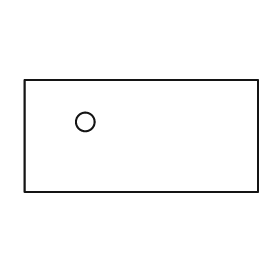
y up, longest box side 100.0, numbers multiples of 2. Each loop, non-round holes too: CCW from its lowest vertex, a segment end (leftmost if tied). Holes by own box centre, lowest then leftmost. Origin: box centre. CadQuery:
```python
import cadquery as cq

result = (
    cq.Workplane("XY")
    .moveTo(-50.0, -24.0)
    .lineTo(50.0, -24.0)
    .lineTo(50.0, 24.0)
    .lineTo(-50.0, 24.0)
    .close()
    .moveTo(-24.0, 6.0)
    .circle(4.0)
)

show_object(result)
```